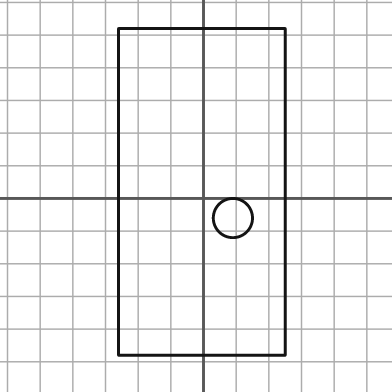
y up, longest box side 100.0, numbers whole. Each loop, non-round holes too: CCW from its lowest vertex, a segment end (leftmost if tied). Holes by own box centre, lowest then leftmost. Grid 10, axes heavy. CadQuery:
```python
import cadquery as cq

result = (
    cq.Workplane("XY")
    .moveTo(-26.0, -48.0)
    .lineTo(25.0, -48.0)
    .lineTo(25.0, 52.0)
    .lineTo(-26.0, 52.0)
    .close()
    .moveTo(9.0, -6.0)
    .circle(6.0)
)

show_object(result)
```